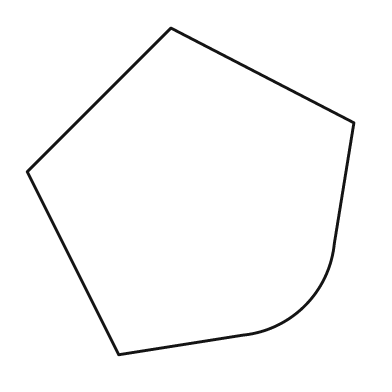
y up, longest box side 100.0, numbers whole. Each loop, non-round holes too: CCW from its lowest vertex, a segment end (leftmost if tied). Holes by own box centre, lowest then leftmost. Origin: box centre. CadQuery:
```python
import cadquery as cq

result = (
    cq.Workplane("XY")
    .moveTo(-22.0, -50.0)
    .lineTo(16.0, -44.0)
    .threePointArc((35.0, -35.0), (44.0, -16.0))
    .lineTo(50.0, 21.0)
    .lineTo(-6.0, 50.0)
    .lineTo(-50.0, 6.0)
    .close()
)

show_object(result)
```